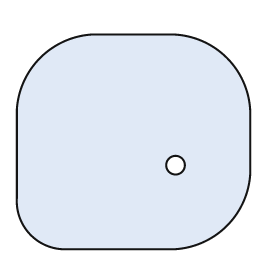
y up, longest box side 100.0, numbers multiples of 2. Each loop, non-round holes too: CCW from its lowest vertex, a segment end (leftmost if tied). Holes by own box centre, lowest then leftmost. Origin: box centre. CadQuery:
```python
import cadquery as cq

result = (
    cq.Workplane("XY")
    .moveTo(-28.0, -46.0)
    .lineTo(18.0, -46.0)
    .threePointArc((40.0, -36.0), (50.0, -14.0))
    .lineTo(50.0, 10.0)
    .threePointArc((40.0, 36.0), (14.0, 46.0))
    .lineTo(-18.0, 46.0)
    .threePointArc((-40.0, 36.0), (-50.0, 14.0))
    .lineTo(-50.0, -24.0)
    .threePointArc((-44.0, -40.0), (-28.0, -46.0))
    .close()
    .moveTo(18.0, -10.0)
    .circle(4.0)
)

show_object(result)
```